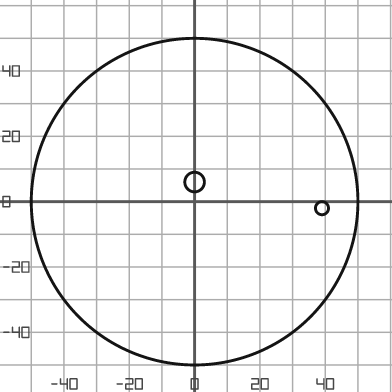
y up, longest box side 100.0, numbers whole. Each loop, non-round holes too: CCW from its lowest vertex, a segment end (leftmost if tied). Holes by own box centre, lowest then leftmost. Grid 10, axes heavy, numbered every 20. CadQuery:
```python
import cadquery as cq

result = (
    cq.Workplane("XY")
    .moveTo(0.0, 0.0)
    .circle(50.0)
    .moveTo(39.0, -2.0)
    .circle(2.0)
    .moveTo(0.0, 6.0)
    .circle(3.0)
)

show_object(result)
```